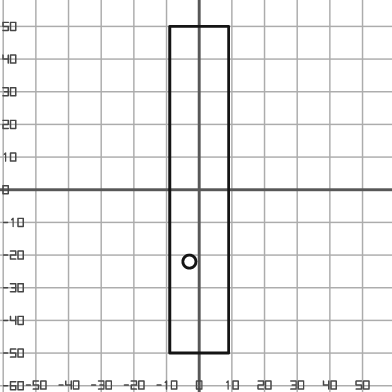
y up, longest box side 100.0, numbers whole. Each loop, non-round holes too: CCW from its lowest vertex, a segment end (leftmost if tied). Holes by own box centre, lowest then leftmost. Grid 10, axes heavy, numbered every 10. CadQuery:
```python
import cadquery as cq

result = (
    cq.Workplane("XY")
    .moveTo(-9.0, -50.0)
    .lineTo(9.0, -50.0)
    .lineTo(9.0, 50.0)
    .lineTo(-9.0, 50.0)
    .close()
    .moveTo(-3.0, -22.0)
    .circle(2.0)
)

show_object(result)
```